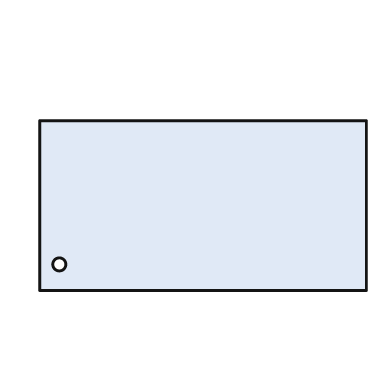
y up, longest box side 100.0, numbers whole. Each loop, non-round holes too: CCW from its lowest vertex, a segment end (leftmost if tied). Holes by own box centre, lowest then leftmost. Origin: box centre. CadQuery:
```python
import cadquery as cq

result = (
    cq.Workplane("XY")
    .moveTo(-50.0, -26.0)
    .lineTo(50.0, -26.0)
    .lineTo(50.0, 26.0)
    .lineTo(-50.0, 26.0)
    .close()
    .moveTo(-44.0, -18.0)
    .circle(2.0)
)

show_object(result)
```